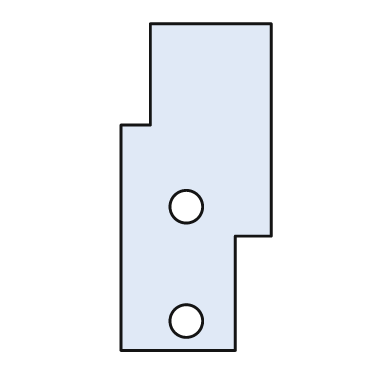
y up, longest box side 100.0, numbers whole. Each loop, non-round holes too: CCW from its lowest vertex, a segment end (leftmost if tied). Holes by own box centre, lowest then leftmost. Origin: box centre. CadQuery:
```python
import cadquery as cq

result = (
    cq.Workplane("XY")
    .moveTo(-23.0, -50.0)
    .lineTo(12.0, -50.0)
    .lineTo(12.0, -15.0)
    .lineTo(23.0, -15.0)
    .lineTo(23.0, 50.0)
    .lineTo(-14.0, 50.0)
    .lineTo(-14.0, 19.0)
    .lineTo(-23.0, 19.0)
    .close()
    .moveTo(-3.0, -41.0)
    .circle(5.0)
    .moveTo(-3.0, -6.0)
    .circle(5.0)
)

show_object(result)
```